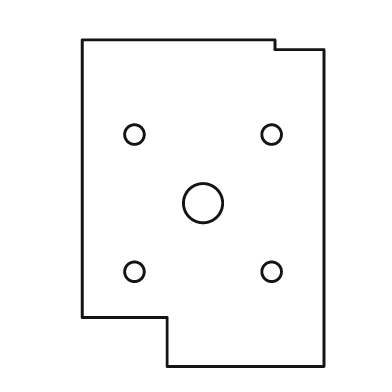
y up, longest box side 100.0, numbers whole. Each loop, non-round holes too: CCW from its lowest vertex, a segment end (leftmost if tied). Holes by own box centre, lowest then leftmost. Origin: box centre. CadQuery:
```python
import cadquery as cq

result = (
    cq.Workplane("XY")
    .moveTo(-11.0, -50.0)
    .lineTo(37.0, -50.0)
    .lineTo(37.0, 47.0)
    .lineTo(22.0, 47.0)
    .lineTo(22.0, 50.0)
    .lineTo(-37.0, 50.0)
    .lineTo(-37.0, -35.0)
    .lineTo(-11.0, -35.0)
    .close()
    .moveTo(-21.0, -21.0)
    .circle(3.0)
    .moveTo(21.0, -21.0)
    .circle(3.0)
    .moveTo(0.0, 0.0)
    .circle(6.0)
    .moveTo(-21.0, 21.0)
    .circle(3.0)
    .moveTo(21.0, 21.0)
    .circle(3.0)
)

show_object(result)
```